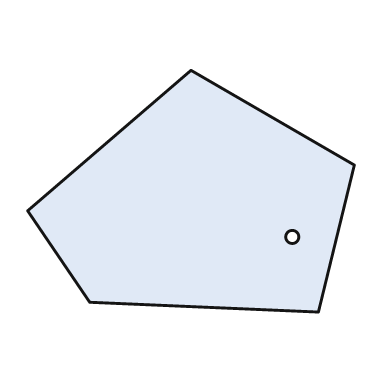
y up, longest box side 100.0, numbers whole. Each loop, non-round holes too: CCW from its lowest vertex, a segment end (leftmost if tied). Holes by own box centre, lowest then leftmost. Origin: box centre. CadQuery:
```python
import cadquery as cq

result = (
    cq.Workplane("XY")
    .moveTo(39.0, -37.0)
    .lineTo(50.0, 8.0)
    .lineTo(0.0, 37.0)
    .lineTo(-50.0, -6.0)
    .lineTo(-31.0, -34.0)
    .close()
    .moveTo(31.0, -14.0)
    .circle(2.0)
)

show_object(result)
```